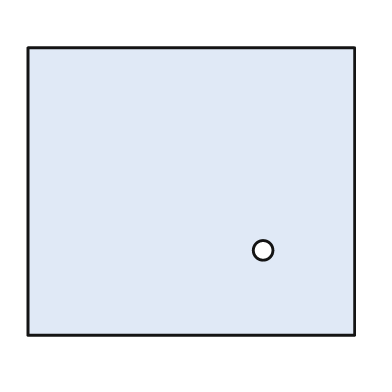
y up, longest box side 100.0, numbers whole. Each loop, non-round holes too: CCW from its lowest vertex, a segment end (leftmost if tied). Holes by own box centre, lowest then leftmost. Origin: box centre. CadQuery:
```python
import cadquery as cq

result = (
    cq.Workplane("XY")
    .moveTo(-50.0, -44.0)
    .lineTo(50.0, -44.0)
    .lineTo(50.0, 44.0)
    .lineTo(-50.0, 44.0)
    .close()
    .moveTo(22.0, -18.0)
    .circle(3.0)
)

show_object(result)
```